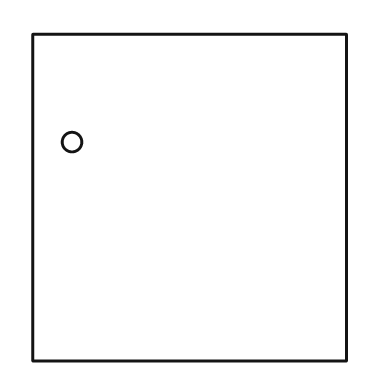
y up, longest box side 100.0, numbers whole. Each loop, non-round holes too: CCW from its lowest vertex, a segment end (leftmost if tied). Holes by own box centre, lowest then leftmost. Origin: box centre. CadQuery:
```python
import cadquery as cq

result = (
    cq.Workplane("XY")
    .moveTo(-48.0, -50.0)
    .lineTo(48.0, -50.0)
    .lineTo(48.0, 50.0)
    .lineTo(-48.0, 50.0)
    .close()
    .moveTo(-36.0, 17.0)
    .circle(3.0)
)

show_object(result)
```